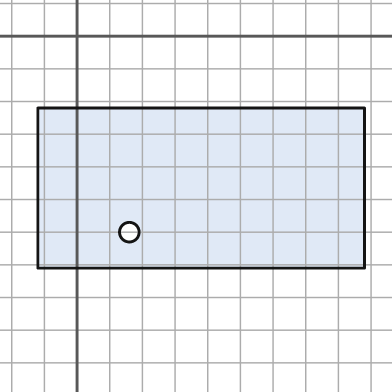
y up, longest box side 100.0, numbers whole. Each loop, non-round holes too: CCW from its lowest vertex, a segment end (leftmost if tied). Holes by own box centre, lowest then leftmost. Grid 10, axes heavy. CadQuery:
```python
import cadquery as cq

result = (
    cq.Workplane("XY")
    .moveTo(-12.0, -71.0)
    .lineTo(88.0, -71.0)
    .lineTo(88.0, -22.0)
    .lineTo(-12.0, -22.0)
    .close()
    .moveTo(16.0, -60.0)
    .circle(3.0)
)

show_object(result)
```